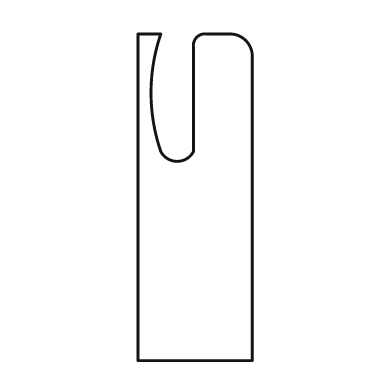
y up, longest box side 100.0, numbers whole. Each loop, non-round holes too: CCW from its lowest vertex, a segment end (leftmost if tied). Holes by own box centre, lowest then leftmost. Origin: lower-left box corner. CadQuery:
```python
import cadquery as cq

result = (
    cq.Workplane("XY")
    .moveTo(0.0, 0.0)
    .lineTo(35.0, 0.0)
    .lineTo(35.0, 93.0)
    .threePointArc((33.0, 98.0), (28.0, 100.0))
    .lineTo(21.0, 100.0)
    .threePointArc((18.0, 99.0), (17.0, 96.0))
    .lineTo(17.0, 64.0)
    .threePointArc((12.0, 61.0), (7.0, 64.0))
    .threePointArc((4.0, 82.0), (7.0, 100.0))
    .lineTo(0.0, 100.0)
    .close()
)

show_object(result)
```